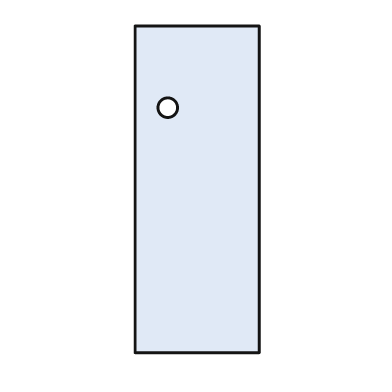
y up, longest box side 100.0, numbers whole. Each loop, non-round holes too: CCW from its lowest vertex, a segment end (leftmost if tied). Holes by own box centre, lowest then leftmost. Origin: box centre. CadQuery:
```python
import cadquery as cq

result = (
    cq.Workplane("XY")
    .moveTo(-19.0, -50.0)
    .lineTo(19.0, -50.0)
    .lineTo(19.0, 50.0)
    .lineTo(-19.0, 50.0)
    .close()
    .moveTo(-9.0, 25.0)
    .circle(3.0)
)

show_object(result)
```